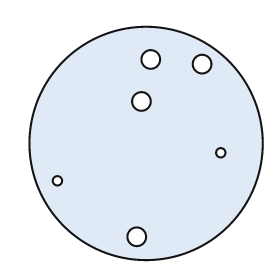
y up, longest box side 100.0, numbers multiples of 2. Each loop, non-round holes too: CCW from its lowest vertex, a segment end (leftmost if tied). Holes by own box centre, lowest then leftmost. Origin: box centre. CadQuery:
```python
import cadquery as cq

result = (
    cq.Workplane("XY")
    .moveTo(0.0, 0.0)
    .circle(50.0)
    .moveTo(-4.0, -40.0)
    .circle(4.0)
    .moveTo(-38.0, -16.0)
    .circle(2.0)
    .moveTo(32.0, -4.0)
    .circle(2.0)
    .moveTo(-2.0, 18.0)
    .circle(4.0)
    .moveTo(24.0, 34.0)
    .circle(4.0)
    .moveTo(2.0, 36.0)
    .circle(4.0)
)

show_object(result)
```